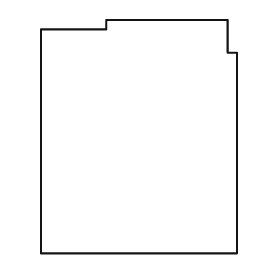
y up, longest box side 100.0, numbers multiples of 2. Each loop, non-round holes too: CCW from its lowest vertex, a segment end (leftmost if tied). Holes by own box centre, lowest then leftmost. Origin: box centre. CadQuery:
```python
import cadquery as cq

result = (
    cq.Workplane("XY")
    .moveTo(-42.0, -50.0)
    .lineTo(42.0, -50.0)
    .lineTo(42.0, 36.0)
    .lineTo(38.0, 36.0)
    .lineTo(38.0, 50.0)
    .lineTo(-14.0, 50.0)
    .lineTo(-14.0, 46.0)
    .lineTo(-42.0, 46.0)
    .close()
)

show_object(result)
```